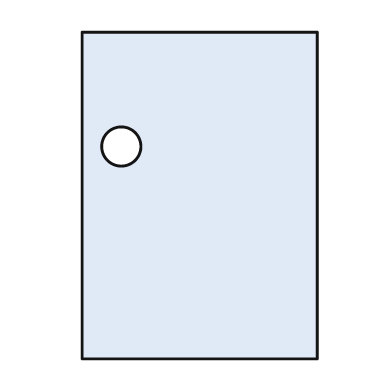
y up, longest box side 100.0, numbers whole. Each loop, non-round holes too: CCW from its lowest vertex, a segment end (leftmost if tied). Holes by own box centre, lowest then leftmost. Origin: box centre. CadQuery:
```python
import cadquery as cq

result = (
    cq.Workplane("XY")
    .moveTo(-36.0, -50.0)
    .lineTo(36.0, -50.0)
    .lineTo(36.0, 50.0)
    .lineTo(-36.0, 50.0)
    .close()
    .moveTo(-24.0, 15.0)
    .circle(6.0)
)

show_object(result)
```